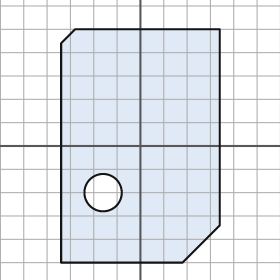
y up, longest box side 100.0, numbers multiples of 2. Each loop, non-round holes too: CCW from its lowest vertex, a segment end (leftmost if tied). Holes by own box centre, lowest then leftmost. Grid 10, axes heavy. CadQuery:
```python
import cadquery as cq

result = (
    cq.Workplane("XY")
    .moveTo(-34.0, -50.0)
    .lineTo(18.0, -50.0)
    .lineTo(34.0, -34.0)
    .lineTo(34.0, 50.0)
    .lineTo(-28.0, 50.0)
    .lineTo(-34.0, 44.0)
    .close()
    .moveTo(-16.0, -20.0)
    .circle(8.0)
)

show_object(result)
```